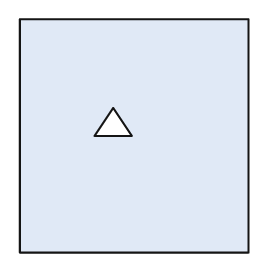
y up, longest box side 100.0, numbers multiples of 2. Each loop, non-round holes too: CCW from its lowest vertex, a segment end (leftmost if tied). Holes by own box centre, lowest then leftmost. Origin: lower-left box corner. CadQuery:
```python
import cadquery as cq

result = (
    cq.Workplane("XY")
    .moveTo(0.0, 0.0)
    .lineTo(98.0, 0.0)
    .lineTo(98.0, 100.0)
    .lineTo(0.0, 100.0)
    .close()
    .moveTo(32.0, 50.0)
    .lineTo(48.0, 50.0)
    .lineTo(40.0, 62.0)
    .close()
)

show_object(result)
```